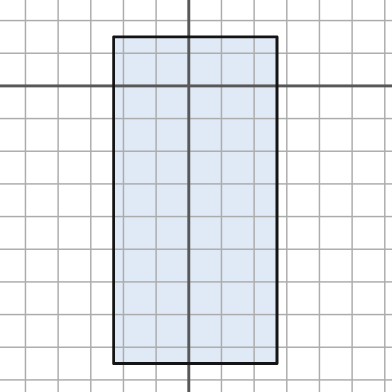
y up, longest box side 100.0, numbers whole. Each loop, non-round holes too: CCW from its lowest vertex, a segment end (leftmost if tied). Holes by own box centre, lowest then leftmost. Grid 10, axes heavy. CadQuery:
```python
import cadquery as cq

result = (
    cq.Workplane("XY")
    .moveTo(-23.0, -85.0)
    .lineTo(27.0, -85.0)
    .lineTo(27.0, 15.0)
    .lineTo(-23.0, 15.0)
    .close()
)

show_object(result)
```